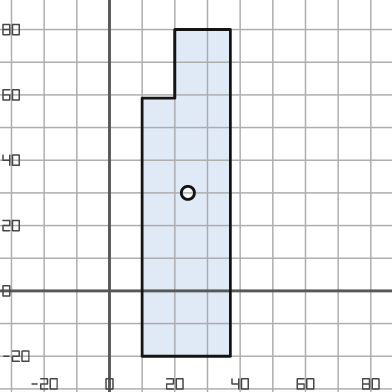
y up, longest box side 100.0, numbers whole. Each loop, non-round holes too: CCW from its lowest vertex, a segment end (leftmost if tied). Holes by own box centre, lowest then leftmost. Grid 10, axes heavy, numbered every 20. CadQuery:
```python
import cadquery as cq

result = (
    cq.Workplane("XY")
    .moveTo(10.0, -20.0)
    .lineTo(37.0, -20.0)
    .lineTo(37.0, 80.0)
    .lineTo(20.0, 80.0)
    .lineTo(20.0, 59.0)
    .lineTo(10.0, 59.0)
    .close()
    .moveTo(24.0, 30.0)
    .circle(2.0)
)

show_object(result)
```